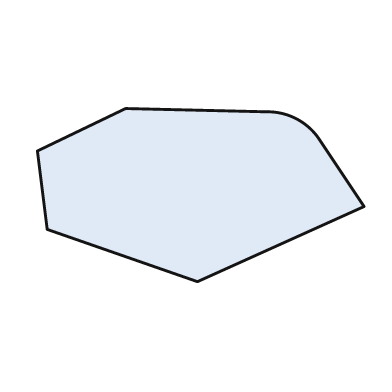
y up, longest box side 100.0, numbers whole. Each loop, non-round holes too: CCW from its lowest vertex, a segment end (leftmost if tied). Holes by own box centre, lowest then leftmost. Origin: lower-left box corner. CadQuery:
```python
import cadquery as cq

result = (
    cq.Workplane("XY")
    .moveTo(49.0, 0.0)
    .lineTo(100.0, 23.0)
    .lineTo(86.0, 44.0)
    .threePointArc((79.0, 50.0), (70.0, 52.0))
    .lineTo(27.0, 53.0)
    .lineTo(0.0, 40.0)
    .lineTo(3.0, 16.0)
    .close()
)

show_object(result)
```